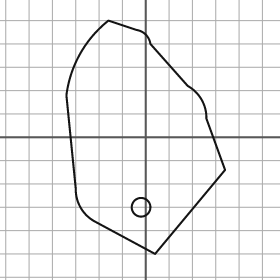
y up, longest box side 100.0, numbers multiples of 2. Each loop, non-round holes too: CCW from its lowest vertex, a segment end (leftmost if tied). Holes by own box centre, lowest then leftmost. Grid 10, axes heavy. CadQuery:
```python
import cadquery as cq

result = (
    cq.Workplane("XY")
    .moveTo(4.0, -50.0)
    .lineTo(34.0, -14.0)
    .lineTo(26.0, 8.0)
    .threePointArc((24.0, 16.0), (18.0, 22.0))
    .lineTo(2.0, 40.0)
    .threePointArc((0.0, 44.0), (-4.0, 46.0))
    .lineTo(-16.0, 50.0)
    .threePointArc((-28.0, 36.0), (-34.0, 18.0))
    .lineTo(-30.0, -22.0)
    .threePointArc((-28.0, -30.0), (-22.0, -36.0))
    .close()
    .moveTo(-2.0, -30.0)
    .circle(4.0)
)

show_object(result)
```